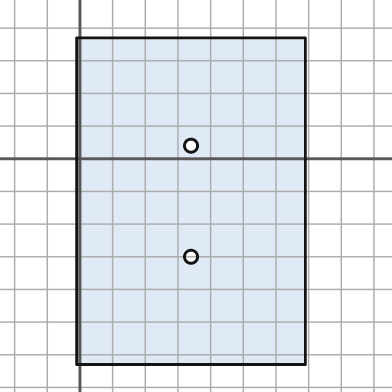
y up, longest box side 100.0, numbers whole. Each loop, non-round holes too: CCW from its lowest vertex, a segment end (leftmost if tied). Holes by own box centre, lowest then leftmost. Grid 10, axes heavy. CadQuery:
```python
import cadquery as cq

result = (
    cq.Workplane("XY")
    .moveTo(-1.0, -63.0)
    .lineTo(69.0, -63.0)
    .lineTo(69.0, 37.0)
    .lineTo(-1.0, 37.0)
    .close()
    .moveTo(34.0, -30.0)
    .circle(2.0)
    .moveTo(34.0, 4.0)
    .circle(2.0)
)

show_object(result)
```